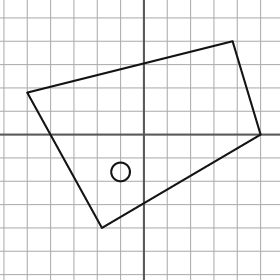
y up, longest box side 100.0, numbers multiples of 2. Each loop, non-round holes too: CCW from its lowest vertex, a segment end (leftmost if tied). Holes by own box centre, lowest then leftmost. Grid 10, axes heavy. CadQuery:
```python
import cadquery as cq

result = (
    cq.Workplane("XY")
    .moveTo(-18.0, -40.0)
    .lineTo(50.0, 0.0)
    .lineTo(38.0, 40.0)
    .lineTo(-50.0, 18.0)
    .close()
    .moveTo(-10.0, -16.0)
    .circle(4.0)
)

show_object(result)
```